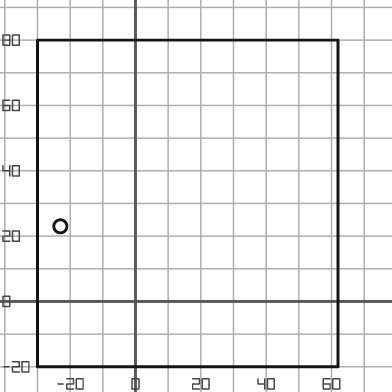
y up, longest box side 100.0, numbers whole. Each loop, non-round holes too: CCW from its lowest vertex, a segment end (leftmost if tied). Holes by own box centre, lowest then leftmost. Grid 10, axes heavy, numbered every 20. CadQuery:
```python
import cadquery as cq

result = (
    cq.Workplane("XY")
    .moveTo(-30.0, -20.0)
    .lineTo(62.0, -20.0)
    .lineTo(62.0, 80.0)
    .lineTo(-30.0, 80.0)
    .close()
    .moveTo(-23.0, 23.0)
    .circle(2.0)
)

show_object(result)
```